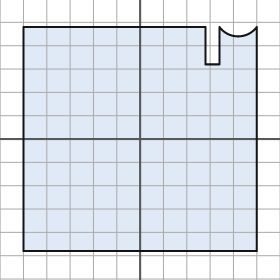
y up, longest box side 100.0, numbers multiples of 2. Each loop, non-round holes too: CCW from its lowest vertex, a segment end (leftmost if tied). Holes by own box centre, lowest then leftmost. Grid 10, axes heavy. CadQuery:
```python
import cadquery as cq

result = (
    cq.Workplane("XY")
    .moveTo(-50.0, -48.0)
    .lineTo(50.0, -48.0)
    .lineTo(50.0, 48.0)
    .threePointArc((42.0, 44.0), (34.0, 48.0))
    .lineTo(34.0, 32.0)
    .lineTo(28.0, 32.0)
    .lineTo(28.0, 48.0)
    .lineTo(-50.0, 48.0)
    .close()
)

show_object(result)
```